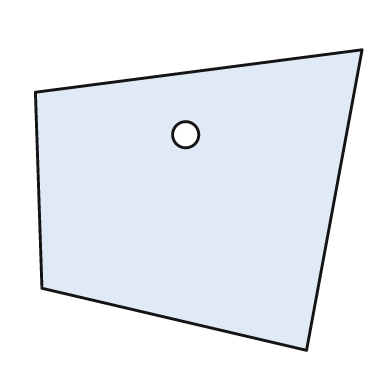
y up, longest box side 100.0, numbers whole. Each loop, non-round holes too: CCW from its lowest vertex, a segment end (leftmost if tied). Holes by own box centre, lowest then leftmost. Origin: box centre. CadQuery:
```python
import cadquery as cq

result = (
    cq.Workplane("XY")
    .moveTo(33.0, -46.0)
    .lineTo(50.0, 46.0)
    .lineTo(-50.0, 33.0)
    .lineTo(-48.0, -27.0)
    .close()
    .moveTo(-4.0, 20.0)
    .circle(4.0)
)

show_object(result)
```